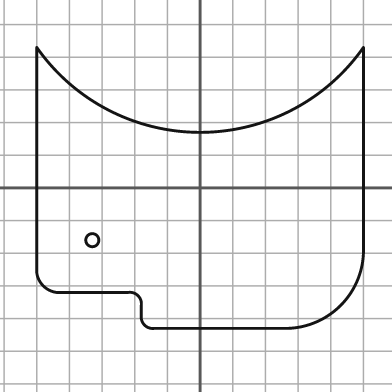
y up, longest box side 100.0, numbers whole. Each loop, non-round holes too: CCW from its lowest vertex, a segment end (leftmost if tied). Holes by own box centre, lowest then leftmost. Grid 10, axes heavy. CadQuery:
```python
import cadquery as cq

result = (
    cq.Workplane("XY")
    .moveTo(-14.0, -43.0)
    .lineTo(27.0, -43.0)
    .threePointArc((43.0, -36.0), (50.0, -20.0))
    .lineTo(50.0, 43.0)
    .threePointArc((0.0, 17.0), (-50.0, 43.0))
    .lineTo(-50.0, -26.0)
    .threePointArc((-48.0, -30.0), (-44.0, -32.0))
    .lineTo(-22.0, -32.0)
    .threePointArc((-19.0, -33.0), (-18.0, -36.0))
    .lineTo(-18.0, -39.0)
    .threePointArc((-17.0, -42.0), (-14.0, -43.0))
    .close()
    .moveTo(-33.0, -16.0)
    .circle(2.0)
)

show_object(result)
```